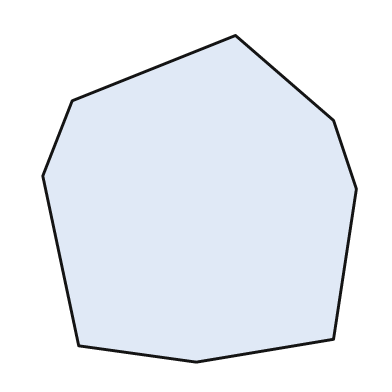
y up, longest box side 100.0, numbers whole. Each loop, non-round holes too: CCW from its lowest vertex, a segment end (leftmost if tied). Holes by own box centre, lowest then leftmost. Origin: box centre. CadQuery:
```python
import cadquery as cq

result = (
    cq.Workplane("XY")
    .moveTo(-1.0, -50.0)
    .lineTo(41.0, -43.0)
    .lineTo(48.0, 3.0)
    .lineTo(41.0, 24.0)
    .lineTo(11.0, 50.0)
    .lineTo(-39.0, 30.0)
    .lineTo(-48.0, 7.0)
    .lineTo(-37.0, -45.0)
    .close()
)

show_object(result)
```